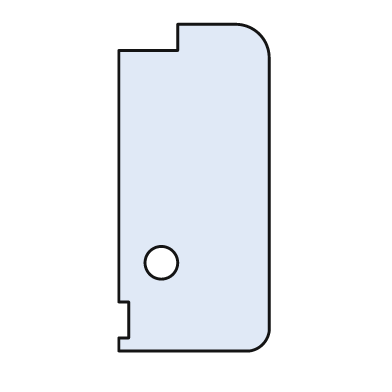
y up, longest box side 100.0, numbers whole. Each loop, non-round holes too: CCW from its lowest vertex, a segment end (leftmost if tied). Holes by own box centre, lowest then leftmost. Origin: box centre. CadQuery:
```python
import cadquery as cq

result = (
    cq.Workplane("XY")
    .moveTo(-23.0, -50.0)
    .lineTo(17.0, -50.0)
    .threePointArc((21.0, -48.0), (23.0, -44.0))
    .lineTo(23.0, 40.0)
    .threePointArc((20.0, 47.0), (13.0, 50.0))
    .lineTo(-5.0, 50.0)
    .lineTo(-5.0, 42.0)
    .lineTo(-23.0, 42.0)
    .lineTo(-23.0, -35.0)
    .lineTo(-20.0, -35.0)
    .lineTo(-20.0, -46.0)
    .lineTo(-23.0, -46.0)
    .close()
    .moveTo(-10.0, -23.0)
    .circle(5.0)
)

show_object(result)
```